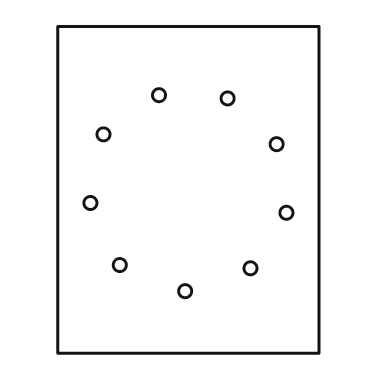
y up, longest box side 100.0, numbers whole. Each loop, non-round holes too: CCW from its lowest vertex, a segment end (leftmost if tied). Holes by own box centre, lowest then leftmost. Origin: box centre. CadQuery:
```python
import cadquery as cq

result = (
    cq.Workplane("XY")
    .moveTo(-40.0, -50.0)
    .lineTo(40.0, -50.0)
    .lineTo(40.0, 50.0)
    .lineTo(-40.0, 50.0)
    .close()
    .moveTo(-1.0, -31.0)
    .circle(2.0)
    .moveTo(19.0, -24.0)
    .circle(2.0)
    .moveTo(-21.0, -23.0)
    .circle(2.0)
    .moveTo(30.0, -7.0)
    .circle(2.0)
    .moveTo(-30.0, -4.0)
    .circle(2.0)
    .moveTo(27.0, 14.0)
    .circle(2.0)
    .moveTo(-26.0, 17.0)
    .circle(2.0)
    .moveTo(12.0, 28.0)
    .circle(2.0)
    .moveTo(-9.0, 29.0)
    .circle(2.0)
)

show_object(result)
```